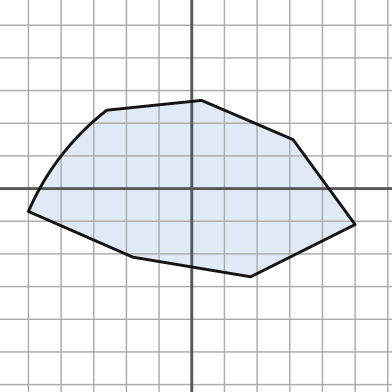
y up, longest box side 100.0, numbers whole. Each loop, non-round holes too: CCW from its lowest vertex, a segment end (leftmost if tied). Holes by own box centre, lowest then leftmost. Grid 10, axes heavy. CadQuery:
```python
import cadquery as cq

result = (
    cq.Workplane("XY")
    .moveTo(18.0, -27.0)
    .lineTo(50.0, -11.0)
    .lineTo(31.0, 15.0)
    .lineTo(3.0, 27.0)
    .lineTo(-26.0, 24.0)
    .threePointArc((-40.0, 10.0), (-50.0, -7.0))
    .lineTo(-18.0, -21.0)
    .close()
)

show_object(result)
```